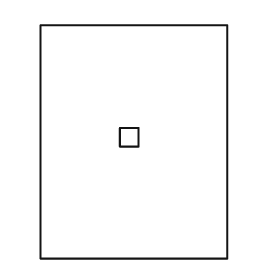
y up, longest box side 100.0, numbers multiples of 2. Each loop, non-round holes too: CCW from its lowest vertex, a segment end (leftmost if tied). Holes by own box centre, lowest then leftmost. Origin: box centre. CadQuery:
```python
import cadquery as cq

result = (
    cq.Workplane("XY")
    .moveTo(-40.0, -50.0)
    .lineTo(40.0, -50.0)
    .lineTo(40.0, 50.0)
    .lineTo(-40.0, 50.0)
    .close()
    .moveTo(-6.0, -2.0)
    .lineTo(2.0, -2.0)
    .lineTo(2.0, 6.0)
    .lineTo(-6.0, 6.0)
    .close()
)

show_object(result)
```